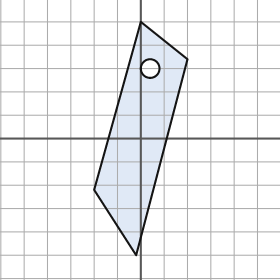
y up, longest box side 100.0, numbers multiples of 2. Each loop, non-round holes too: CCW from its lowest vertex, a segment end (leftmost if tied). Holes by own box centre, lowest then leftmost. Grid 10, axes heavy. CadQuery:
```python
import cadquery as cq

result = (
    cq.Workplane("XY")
    .moveTo(-2.0, -50.0)
    .lineTo(20.0, 34.0)
    .lineTo(0.0, 50.0)
    .lineTo(-20.0, -22.0)
    .close()
    .moveTo(4.0, 30.0)
    .circle(4.0)
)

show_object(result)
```